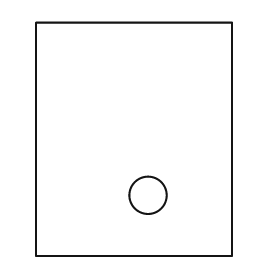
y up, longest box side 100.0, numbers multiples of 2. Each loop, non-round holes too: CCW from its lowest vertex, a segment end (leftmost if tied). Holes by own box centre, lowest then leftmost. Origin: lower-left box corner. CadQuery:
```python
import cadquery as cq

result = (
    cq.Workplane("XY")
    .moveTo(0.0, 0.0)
    .lineTo(84.0, 0.0)
    .lineTo(84.0, 100.0)
    .lineTo(0.0, 100.0)
    .close()
    .moveTo(48.0, 26.0)
    .circle(8.0)
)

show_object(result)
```